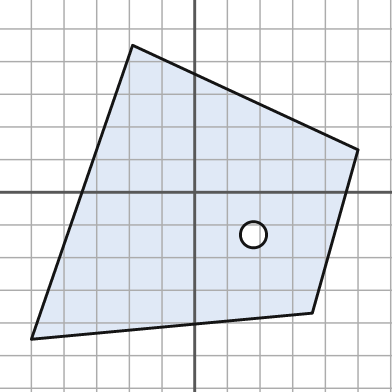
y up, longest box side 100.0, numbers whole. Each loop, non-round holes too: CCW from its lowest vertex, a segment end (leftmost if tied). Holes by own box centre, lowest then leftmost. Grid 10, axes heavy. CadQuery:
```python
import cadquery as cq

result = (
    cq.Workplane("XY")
    .moveTo(-50.0, -45.0)
    .lineTo(36.0, -37.0)
    .lineTo(50.0, 13.0)
    .lineTo(-19.0, 45.0)
    .close()
    .moveTo(18.0, -13.0)
    .circle(4.0)
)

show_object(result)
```